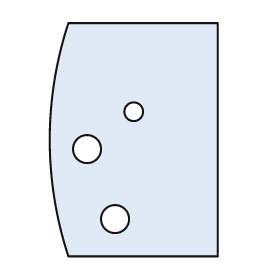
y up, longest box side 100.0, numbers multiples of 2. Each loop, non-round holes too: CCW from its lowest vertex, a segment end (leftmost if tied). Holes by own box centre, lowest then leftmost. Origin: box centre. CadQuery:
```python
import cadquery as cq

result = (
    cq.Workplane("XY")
    .moveTo(-28.0, -50.0)
    .lineTo(36.0, -50.0)
    .lineTo(36.0, 50.0)
    .lineTo(-28.0, 50.0)
    .threePointArc((-36.0, 0.0), (-28.0, -50.0))
    .close()
    .moveTo(-8.0, -34.0)
    .circle(6.0)
    .moveTo(-20.0, -4.0)
    .circle(6.0)
    .moveTo(0.0, 12.0)
    .circle(4.0)
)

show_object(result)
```